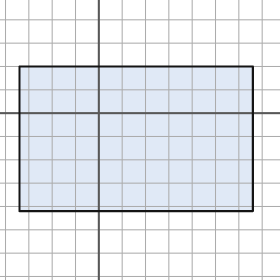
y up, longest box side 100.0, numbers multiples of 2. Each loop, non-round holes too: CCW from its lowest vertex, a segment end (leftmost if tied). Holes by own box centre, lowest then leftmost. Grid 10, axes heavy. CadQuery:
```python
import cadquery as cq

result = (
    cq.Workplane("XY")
    .moveTo(-34.0, -42.0)
    .lineTo(66.0, -42.0)
    .lineTo(66.0, 20.0)
    .lineTo(-34.0, 20.0)
    .close()
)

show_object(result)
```